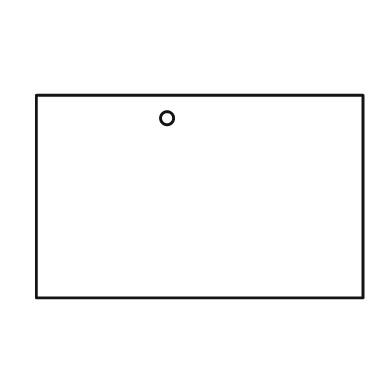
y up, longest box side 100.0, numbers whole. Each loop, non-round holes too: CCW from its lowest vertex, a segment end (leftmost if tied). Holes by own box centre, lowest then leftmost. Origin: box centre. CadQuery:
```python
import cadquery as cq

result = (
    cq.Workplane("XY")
    .moveTo(-50.0, -31.0)
    .lineTo(50.0, -31.0)
    .lineTo(50.0, 31.0)
    .lineTo(-50.0, 31.0)
    .close()
    .moveTo(-10.0, 24.0)
    .circle(2.0)
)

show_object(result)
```